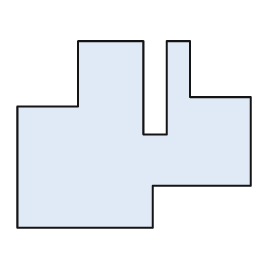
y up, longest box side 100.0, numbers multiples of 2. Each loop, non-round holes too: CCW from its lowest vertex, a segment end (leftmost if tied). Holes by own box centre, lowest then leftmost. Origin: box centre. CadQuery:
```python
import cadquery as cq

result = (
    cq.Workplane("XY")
    .moveTo(-50.0, -40.0)
    .lineTo(8.0, -40.0)
    .lineTo(8.0, -22.0)
    .lineTo(50.0, -22.0)
    .lineTo(50.0, 16.0)
    .lineTo(24.0, 16.0)
    .lineTo(24.0, 40.0)
    .lineTo(14.0, 40.0)
    .lineTo(14.0, 0.0)
    .lineTo(4.0, 0.0)
    .lineTo(4.0, 40.0)
    .lineTo(-24.0, 40.0)
    .lineTo(-24.0, 12.0)
    .lineTo(-50.0, 12.0)
    .close()
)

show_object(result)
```